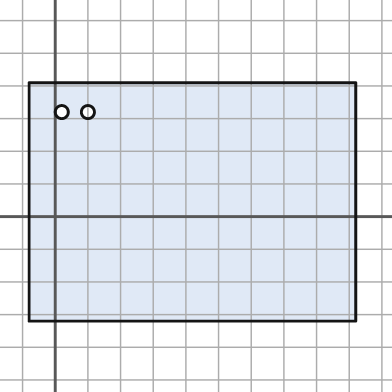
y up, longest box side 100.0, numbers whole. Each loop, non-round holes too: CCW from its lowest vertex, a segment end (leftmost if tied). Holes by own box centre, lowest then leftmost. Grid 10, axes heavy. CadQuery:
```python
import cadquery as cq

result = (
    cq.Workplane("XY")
    .moveTo(-8.0, -32.0)
    .lineTo(92.0, -32.0)
    .lineTo(92.0, 41.0)
    .lineTo(-8.0, 41.0)
    .close()
    .moveTo(2.0, 32.0)
    .circle(2.0)
    .moveTo(10.0, 32.0)
    .circle(2.0)
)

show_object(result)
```